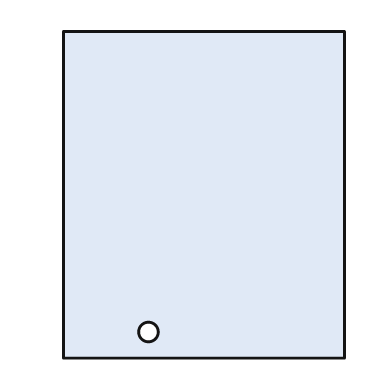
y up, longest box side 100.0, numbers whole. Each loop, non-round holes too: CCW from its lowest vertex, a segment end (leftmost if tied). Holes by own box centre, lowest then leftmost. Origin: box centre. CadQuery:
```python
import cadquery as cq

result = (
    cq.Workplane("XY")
    .moveTo(-43.0, -50.0)
    .lineTo(43.0, -50.0)
    .lineTo(43.0, 50.0)
    .lineTo(-43.0, 50.0)
    .close()
    .moveTo(-17.0, -42.0)
    .circle(3.0)
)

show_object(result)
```